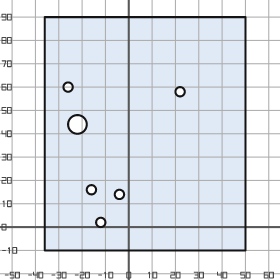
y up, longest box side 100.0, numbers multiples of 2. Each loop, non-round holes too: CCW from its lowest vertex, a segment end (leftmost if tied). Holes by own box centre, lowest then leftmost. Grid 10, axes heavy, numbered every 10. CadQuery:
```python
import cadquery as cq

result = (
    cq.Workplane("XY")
    .moveTo(-36.0, -10.0)
    .lineTo(50.0, -10.0)
    .lineTo(50.0, 90.0)
    .lineTo(-36.0, 90.0)
    .close()
    .moveTo(-12.0, 2.0)
    .circle(2.0)
    .moveTo(-4.0, 14.0)
    .circle(2.0)
    .moveTo(-16.0, 16.0)
    .circle(2.0)
    .moveTo(-22.0, 44.0)
    .circle(4.0)
    .moveTo(22.0, 58.0)
    .circle(2.0)
    .moveTo(-26.0, 60.0)
    .circle(2.0)
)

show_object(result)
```